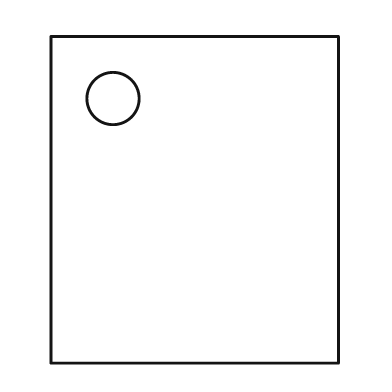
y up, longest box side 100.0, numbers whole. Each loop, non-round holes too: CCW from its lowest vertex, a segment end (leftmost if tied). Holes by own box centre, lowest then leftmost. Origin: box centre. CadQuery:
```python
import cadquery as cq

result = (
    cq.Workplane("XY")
    .moveTo(-44.0, -50.0)
    .lineTo(44.0, -50.0)
    .lineTo(44.0, 50.0)
    .lineTo(-44.0, 50.0)
    .close()
    .moveTo(-25.0, 31.0)
    .circle(8.0)
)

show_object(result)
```